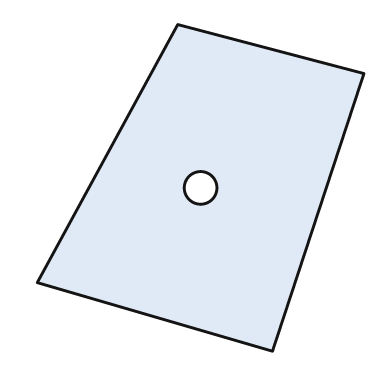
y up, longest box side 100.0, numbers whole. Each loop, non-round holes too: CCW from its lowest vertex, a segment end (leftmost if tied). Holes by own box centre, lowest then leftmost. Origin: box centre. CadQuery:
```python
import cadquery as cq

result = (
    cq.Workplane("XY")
    .moveTo(22.0, -50.0)
    .lineTo(50.0, 35.0)
    .lineTo(-7.0, 50.0)
    .lineTo(-50.0, -29.0)
    .close()
    .moveTo(0.0, 0.0)
    .circle(5.0)
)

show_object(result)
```